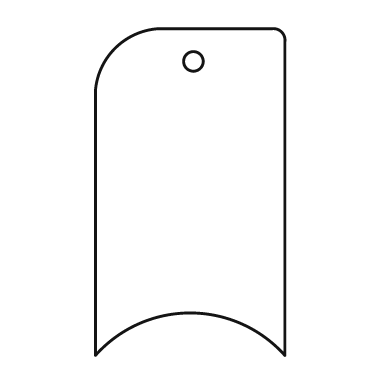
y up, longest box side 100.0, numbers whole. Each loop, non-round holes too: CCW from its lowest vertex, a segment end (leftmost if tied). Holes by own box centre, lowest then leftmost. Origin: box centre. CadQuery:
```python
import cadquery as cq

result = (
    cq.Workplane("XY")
    .moveTo(-29.0, -50.0)
    .threePointArc((0.0, -37.0), (29.0, -50.0))
    .lineTo(29.0, 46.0)
    .threePointArc((28.0, 49.0), (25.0, 50.0))
    .lineTo(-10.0, 50.0)
    .threePointArc((-23.0, 44.0), (-29.0, 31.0))
    .close()
    .moveTo(1.0, 40.0)
    .circle(3.0)
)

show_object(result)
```